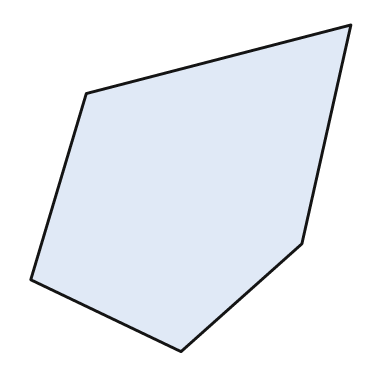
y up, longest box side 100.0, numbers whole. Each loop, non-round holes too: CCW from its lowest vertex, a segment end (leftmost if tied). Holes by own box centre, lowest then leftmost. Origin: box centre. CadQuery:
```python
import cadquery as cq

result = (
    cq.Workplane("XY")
    .moveTo(-3.0, -50.0)
    .lineTo(34.0, -17.0)
    .lineTo(49.0, 50.0)
    .lineTo(-32.0, 29.0)
    .lineTo(-49.0, -28.0)
    .close()
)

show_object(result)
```